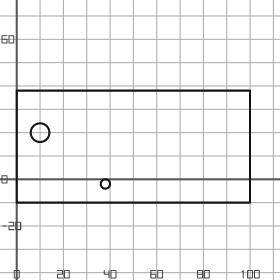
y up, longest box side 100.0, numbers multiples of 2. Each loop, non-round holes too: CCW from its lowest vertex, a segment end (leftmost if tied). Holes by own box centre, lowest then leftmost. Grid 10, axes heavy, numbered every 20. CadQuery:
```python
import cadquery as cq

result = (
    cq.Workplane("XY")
    .moveTo(0.0, -10.0)
    .lineTo(100.0, -10.0)
    .lineTo(100.0, 38.0)
    .lineTo(0.0, 38.0)
    .close()
    .moveTo(38.0, -2.0)
    .circle(2.0)
    .moveTo(10.0, 20.0)
    .circle(4.0)
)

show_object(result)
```